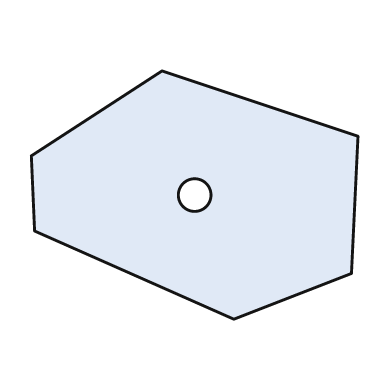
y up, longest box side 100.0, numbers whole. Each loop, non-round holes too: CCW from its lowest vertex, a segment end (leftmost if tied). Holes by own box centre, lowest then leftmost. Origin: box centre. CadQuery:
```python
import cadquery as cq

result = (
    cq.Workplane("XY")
    .moveTo(12.0, -38.0)
    .lineTo(48.0, -24.0)
    .lineTo(50.0, 18.0)
    .lineTo(-10.0, 38.0)
    .lineTo(-50.0, 12.0)
    .lineTo(-49.0, -11.0)
    .close()
    .moveTo(0.0, 0.0)
    .circle(5.0)
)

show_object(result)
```